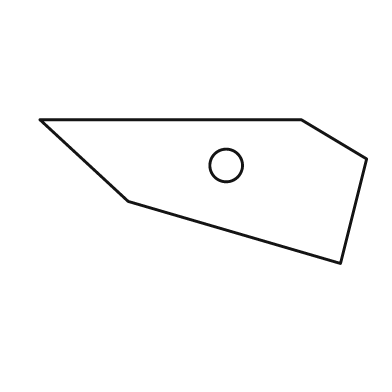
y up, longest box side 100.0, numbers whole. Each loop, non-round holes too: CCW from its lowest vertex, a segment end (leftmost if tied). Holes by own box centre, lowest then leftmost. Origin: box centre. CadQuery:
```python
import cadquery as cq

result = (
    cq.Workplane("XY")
    .moveTo(42.0, -22.0)
    .lineTo(50.0, 10.0)
    .lineTo(30.0, 22.0)
    .lineTo(-50.0, 22.0)
    .lineTo(-23.0, -3.0)
    .close()
    .moveTo(7.0, 8.0)
    .circle(5.0)
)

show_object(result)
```